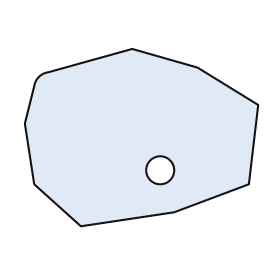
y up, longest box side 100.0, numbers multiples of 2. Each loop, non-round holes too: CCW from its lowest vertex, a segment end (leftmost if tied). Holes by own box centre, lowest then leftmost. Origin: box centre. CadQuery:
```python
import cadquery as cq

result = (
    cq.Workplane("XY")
    .moveTo(-26.0, -38.0)
    .lineTo(14.0, -32.0)
    .lineTo(46.0, -20.0)
    .lineTo(50.0, 14.0)
    .lineTo(24.0, 30.0)
    .lineTo(-4.0, 38.0)
    .lineTo(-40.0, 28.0)
    .threePointArc((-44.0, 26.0), (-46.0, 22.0))
    .lineTo(-50.0, 6.0)
    .lineTo(-46.0, -20.0)
    .close()
    .moveTo(8.0, -14.0)
    .circle(6.0)
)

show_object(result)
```